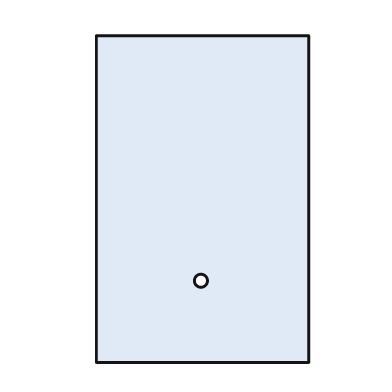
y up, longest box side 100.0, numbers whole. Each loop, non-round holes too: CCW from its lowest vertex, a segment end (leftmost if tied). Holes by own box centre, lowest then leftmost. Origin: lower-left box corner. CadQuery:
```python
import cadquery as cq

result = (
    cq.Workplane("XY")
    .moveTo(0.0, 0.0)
    .lineTo(65.0, 0.0)
    .lineTo(65.0, 100.0)
    .lineTo(0.0, 100.0)
    .close()
    .moveTo(32.0, 25.0)
    .circle(2.0)
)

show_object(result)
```